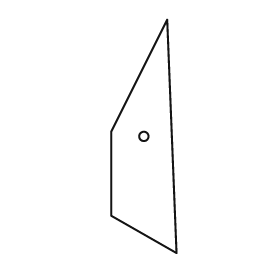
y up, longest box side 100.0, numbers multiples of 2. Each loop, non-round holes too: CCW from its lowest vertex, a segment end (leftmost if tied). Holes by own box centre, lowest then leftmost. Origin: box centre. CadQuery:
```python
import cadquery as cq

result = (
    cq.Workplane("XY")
    .moveTo(14.0, -50.0)
    .lineTo(10.0, 50.0)
    .lineTo(-14.0, 2.0)
    .lineTo(-14.0, -34.0)
    .close()
    .moveTo(0.0, 0.0)
    .circle(2.0)
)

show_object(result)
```